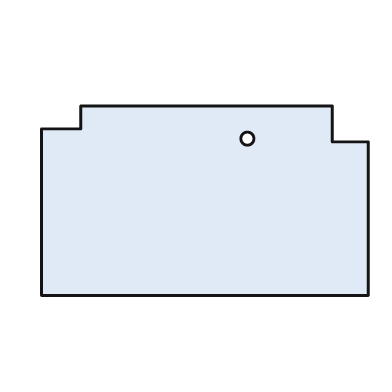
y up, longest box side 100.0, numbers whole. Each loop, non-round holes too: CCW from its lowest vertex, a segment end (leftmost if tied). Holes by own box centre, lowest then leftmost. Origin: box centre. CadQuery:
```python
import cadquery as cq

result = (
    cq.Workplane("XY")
    .moveTo(-50.0, -29.0)
    .lineTo(50.0, -29.0)
    .lineTo(50.0, 18.0)
    .lineTo(39.0, 18.0)
    .lineTo(39.0, 29.0)
    .lineTo(-38.0, 29.0)
    .lineTo(-38.0, 22.0)
    .lineTo(-50.0, 22.0)
    .close()
    .moveTo(13.0, 19.0)
    .circle(2.0)
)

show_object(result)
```